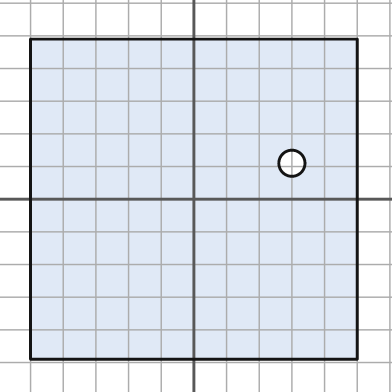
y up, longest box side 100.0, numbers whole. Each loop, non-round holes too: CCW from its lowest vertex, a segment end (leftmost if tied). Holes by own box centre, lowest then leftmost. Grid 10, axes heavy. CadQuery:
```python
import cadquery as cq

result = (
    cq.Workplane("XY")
    .moveTo(-50.0, -49.0)
    .lineTo(50.0, -49.0)
    .lineTo(50.0, 49.0)
    .lineTo(-50.0, 49.0)
    .close()
    .moveTo(30.0, 11.0)
    .circle(4.0)
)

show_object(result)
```